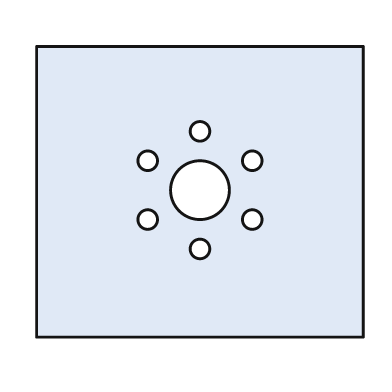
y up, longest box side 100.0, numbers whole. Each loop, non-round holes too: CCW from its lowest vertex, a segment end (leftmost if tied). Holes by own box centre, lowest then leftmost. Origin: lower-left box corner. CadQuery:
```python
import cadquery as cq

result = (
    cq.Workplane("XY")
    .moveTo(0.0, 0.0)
    .lineTo(100.0, 0.0)
    .lineTo(100.0, 89.0)
    .lineTo(0.0, 89.0)
    .close()
    .moveTo(50.0, 27.0)
    .circle(3.0)
    .moveTo(34.0, 36.0)
    .circle(3.0)
    .moveTo(66.0, 36.0)
    .circle(3.0)
    .moveTo(50.0, 45.0)
    .circle(9.0)
    .moveTo(34.0, 54.0)
    .circle(3.0)
    .moveTo(66.0, 54.0)
    .circle(3.0)
    .moveTo(50.0, 63.0)
    .circle(3.0)
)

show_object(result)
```